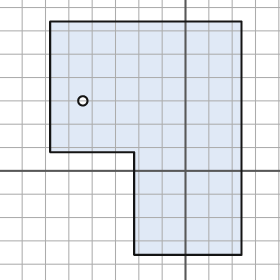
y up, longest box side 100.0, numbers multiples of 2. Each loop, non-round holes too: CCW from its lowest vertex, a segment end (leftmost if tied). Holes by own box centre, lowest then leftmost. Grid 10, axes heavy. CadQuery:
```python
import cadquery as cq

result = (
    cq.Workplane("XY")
    .moveTo(-22.0, -36.0)
    .lineTo(24.0, -36.0)
    .lineTo(24.0, 64.0)
    .lineTo(-58.0, 64.0)
    .lineTo(-58.0, 8.0)
    .lineTo(-22.0, 8.0)
    .close()
    .moveTo(-44.0, 30.0)
    .circle(2.0)
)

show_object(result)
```